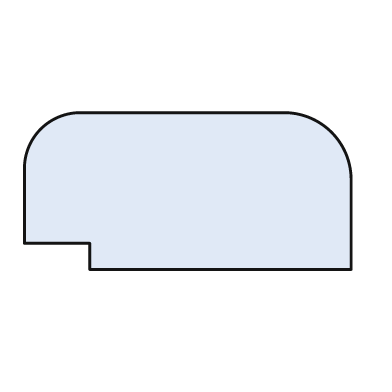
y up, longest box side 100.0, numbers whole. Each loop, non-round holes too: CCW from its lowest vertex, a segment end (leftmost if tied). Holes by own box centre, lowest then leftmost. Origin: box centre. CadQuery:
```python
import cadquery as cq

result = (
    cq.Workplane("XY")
    .moveTo(-30.0, -24.0)
    .lineTo(50.0, -24.0)
    .lineTo(50.0, 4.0)
    .threePointArc((44.0, 18.0), (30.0, 24.0))
    .lineTo(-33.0, 24.0)
    .threePointArc((-45.0, 19.0), (-50.0, 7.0))
    .lineTo(-50.0, -16.0)
    .lineTo(-30.0, -16.0)
    .close()
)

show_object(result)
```